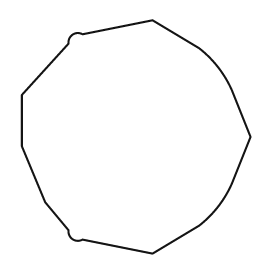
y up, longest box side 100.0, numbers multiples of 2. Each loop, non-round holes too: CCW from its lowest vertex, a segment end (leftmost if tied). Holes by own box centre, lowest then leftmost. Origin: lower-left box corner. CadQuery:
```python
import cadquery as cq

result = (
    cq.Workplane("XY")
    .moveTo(56.0, 0.0)
    .lineTo(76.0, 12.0)
    .threePointArc((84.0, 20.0), (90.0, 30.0))
    .lineTo(98.0, 50.0)
    .lineTo(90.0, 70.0)
    .threePointArc((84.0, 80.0), (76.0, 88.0))
    .lineTo(56.0, 100.0)
    .lineTo(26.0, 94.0)
    .threePointArc((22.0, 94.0), (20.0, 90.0))
    .lineTo(0.0, 68.0)
    .lineTo(0.0, 46.0)
    .lineTo(10.0, 22.0)
    .lineTo(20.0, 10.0)
    .threePointArc((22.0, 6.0), (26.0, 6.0))
    .close()
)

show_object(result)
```